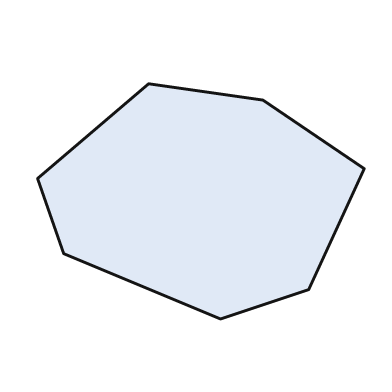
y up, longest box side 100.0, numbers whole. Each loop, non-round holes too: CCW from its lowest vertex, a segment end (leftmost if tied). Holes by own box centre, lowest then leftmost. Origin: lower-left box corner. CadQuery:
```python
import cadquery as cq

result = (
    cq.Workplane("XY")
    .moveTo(56.0, 0.0)
    .lineTo(83.0, 9.0)
    .lineTo(100.0, 46.0)
    .lineTo(69.0, 67.0)
    .lineTo(34.0, 72.0)
    .lineTo(0.0, 43.0)
    .lineTo(8.0, 20.0)
    .close()
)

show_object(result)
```